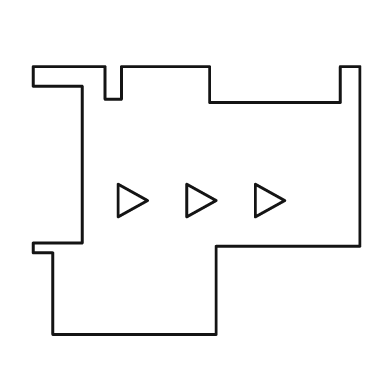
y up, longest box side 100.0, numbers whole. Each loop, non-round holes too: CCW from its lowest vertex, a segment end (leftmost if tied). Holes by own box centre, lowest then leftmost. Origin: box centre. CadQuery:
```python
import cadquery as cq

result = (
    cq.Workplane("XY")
    .moveTo(-44.0, -41.0)
    .lineTo(6.0, -41.0)
    .lineTo(6.0, -14.0)
    .lineTo(50.0, -14.0)
    .lineTo(50.0, 41.0)
    .lineTo(44.0, 41.0)
    .lineTo(44.0, 30.0)
    .lineTo(4.0, 30.0)
    .lineTo(4.0, 41.0)
    .lineTo(-23.0, 41.0)
    .lineTo(-23.0, 31.0)
    .lineTo(-28.0, 31.0)
    .lineTo(-28.0, 41.0)
    .lineTo(-50.0, 41.0)
    .lineTo(-50.0, 35.0)
    .lineTo(-35.0, 35.0)
    .lineTo(-35.0, -13.0)
    .lineTo(-50.0, -13.0)
    .lineTo(-50.0, -16.0)
    .lineTo(-44.0, -16.0)
    .close()
    .moveTo(-24.0, -5.0)
    .lineTo(-15.0, 0.0)
    .lineTo(-24.0, 5.0)
    .close()
    .moveTo(-3.0, -5.0)
    .lineTo(6.0, 0.0)
    .lineTo(-3.0, 5.0)
    .close()
    .moveTo(18.0, -5.0)
    .lineTo(27.0, 0.0)
    .lineTo(18.0, 5.0)
    .close()
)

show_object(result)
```